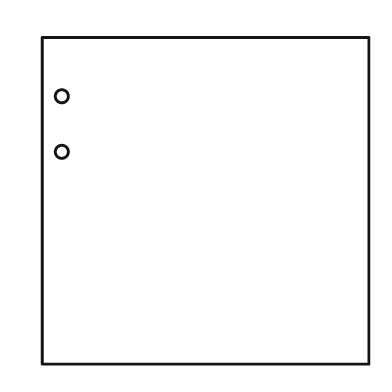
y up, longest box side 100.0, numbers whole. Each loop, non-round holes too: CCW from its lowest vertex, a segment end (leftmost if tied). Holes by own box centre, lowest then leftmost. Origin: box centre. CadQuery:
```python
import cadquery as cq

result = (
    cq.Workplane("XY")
    .moveTo(-50.0, -50.0)
    .lineTo(50.0, -50.0)
    .lineTo(50.0, 50.0)
    .lineTo(-50.0, 50.0)
    .close()
    .moveTo(-44.0, 15.0)
    .circle(2.0)
    .moveTo(-44.0, 32.0)
    .circle(2.0)
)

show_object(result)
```